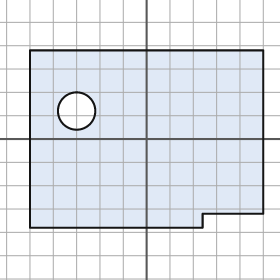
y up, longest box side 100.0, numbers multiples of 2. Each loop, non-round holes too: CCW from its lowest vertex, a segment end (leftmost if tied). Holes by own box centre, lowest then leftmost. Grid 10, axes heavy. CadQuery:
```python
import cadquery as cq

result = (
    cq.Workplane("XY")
    .moveTo(-50.0, -38.0)
    .lineTo(24.0, -38.0)
    .lineTo(24.0, -32.0)
    .lineTo(50.0, -32.0)
    .lineTo(50.0, 38.0)
    .lineTo(-50.0, 38.0)
    .close()
    .moveTo(-30.0, 12.0)
    .circle(8.0)
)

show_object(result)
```